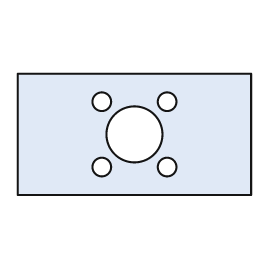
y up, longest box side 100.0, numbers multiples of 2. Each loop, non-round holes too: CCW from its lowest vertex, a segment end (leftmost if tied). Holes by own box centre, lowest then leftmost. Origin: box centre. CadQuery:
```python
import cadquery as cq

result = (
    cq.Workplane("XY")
    .moveTo(-50.0, -26.0)
    .lineTo(50.0, -26.0)
    .lineTo(50.0, 26.0)
    .lineTo(-50.0, 26.0)
    .close()
    .moveTo(-14.0, -14.0)
    .circle(4.0)
    .moveTo(14.0, -14.0)
    .circle(4.0)
    .moveTo(0.0, 0.0)
    .circle(12.0)
    .moveTo(-14.0, 14.0)
    .circle(4.0)
    .moveTo(14.0, 14.0)
    .circle(4.0)
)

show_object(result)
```